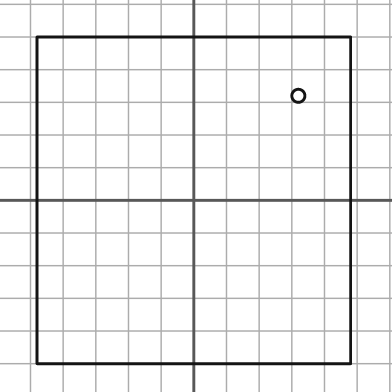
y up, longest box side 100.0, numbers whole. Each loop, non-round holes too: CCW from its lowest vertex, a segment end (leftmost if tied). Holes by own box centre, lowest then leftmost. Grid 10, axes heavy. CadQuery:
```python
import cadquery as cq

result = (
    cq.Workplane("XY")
    .moveTo(-48.0, -50.0)
    .lineTo(48.0, -50.0)
    .lineTo(48.0, 50.0)
    .lineTo(-48.0, 50.0)
    .close()
    .moveTo(32.0, 32.0)
    .circle(2.0)
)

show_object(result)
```